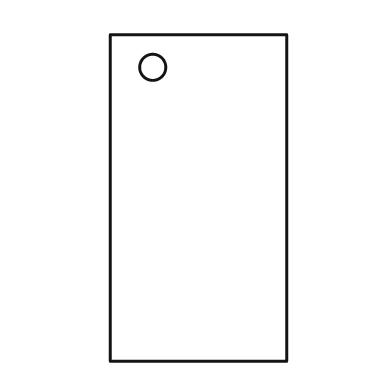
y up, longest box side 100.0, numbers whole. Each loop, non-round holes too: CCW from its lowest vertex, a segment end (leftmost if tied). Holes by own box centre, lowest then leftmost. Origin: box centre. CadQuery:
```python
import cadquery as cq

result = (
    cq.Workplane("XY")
    .moveTo(-27.0, -50.0)
    .lineTo(27.0, -50.0)
    .lineTo(27.0, 50.0)
    .lineTo(-27.0, 50.0)
    .close()
    .moveTo(-14.0, 40.0)
    .circle(4.0)
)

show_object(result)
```